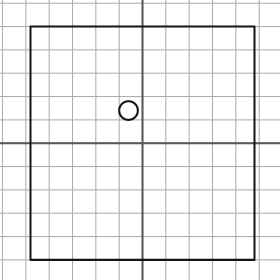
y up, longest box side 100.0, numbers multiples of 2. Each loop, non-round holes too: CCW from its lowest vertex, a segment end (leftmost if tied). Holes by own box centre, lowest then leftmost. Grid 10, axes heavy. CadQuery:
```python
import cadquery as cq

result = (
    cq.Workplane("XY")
    .moveTo(-48.0, -50.0)
    .lineTo(48.0, -50.0)
    .lineTo(48.0, 50.0)
    .lineTo(-48.0, 50.0)
    .close()
    .moveTo(-6.0, 14.0)
    .circle(4.0)
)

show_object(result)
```